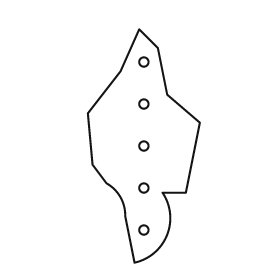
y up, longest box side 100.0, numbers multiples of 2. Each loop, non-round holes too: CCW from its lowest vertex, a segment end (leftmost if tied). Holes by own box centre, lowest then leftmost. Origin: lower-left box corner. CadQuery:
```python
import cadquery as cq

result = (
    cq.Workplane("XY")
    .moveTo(20.0, 0.0)
    .threePointArc((34.0, 12.0), (32.0, 30.0))
    .lineTo(42.0, 30.0)
    .lineTo(48.0, 60.0)
    .lineTo(34.0, 72.0)
    .lineTo(30.0, 92.0)
    .lineTo(22.0, 100.0)
    .lineTo(14.0, 82.0)
    .lineTo(0.0, 64.0)
    .lineTo(2.0, 42.0)
    .lineTo(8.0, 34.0)
    .threePointArc((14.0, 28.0), (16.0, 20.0))
    .close()
    .moveTo(24.0, 14.0)
    .circle(2.0)
    .moveTo(24.0, 32.0)
    .circle(2.0)
    .moveTo(24.0, 50.0)
    .circle(2.0)
    .moveTo(24.0, 68.0)
    .circle(2.0)
    .moveTo(24.0, 86.0)
    .circle(2.0)
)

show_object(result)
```